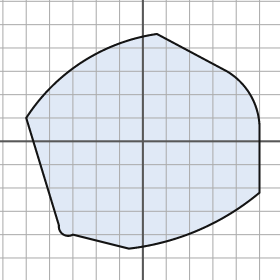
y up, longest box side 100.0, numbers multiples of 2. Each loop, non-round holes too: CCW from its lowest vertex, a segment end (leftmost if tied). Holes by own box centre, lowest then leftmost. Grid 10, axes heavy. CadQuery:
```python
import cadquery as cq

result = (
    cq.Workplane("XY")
    .moveTo(-6.0, -46.0)
    .threePointArc((24.0, -38.0), (50.0, -22.0))
    .lineTo(50.0, 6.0)
    .threePointArc((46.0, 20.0), (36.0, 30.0))
    .lineTo(6.0, 46.0)
    .threePointArc((-26.0, 34.0), (-50.0, 10.0))
    .lineTo(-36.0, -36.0)
    .threePointArc((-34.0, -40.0), (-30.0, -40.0))
    .close()
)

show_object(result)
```